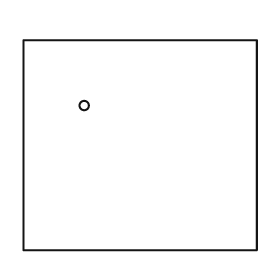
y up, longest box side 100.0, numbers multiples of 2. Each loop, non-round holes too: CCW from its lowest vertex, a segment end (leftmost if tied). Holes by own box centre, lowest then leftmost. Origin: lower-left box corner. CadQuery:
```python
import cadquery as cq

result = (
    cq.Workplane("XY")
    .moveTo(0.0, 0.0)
    .lineTo(100.0, 0.0)
    .lineTo(100.0, 90.0)
    .lineTo(0.0, 90.0)
    .close()
    .moveTo(26.0, 62.0)
    .circle(2.0)
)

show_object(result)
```